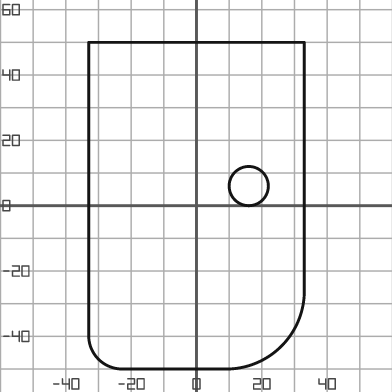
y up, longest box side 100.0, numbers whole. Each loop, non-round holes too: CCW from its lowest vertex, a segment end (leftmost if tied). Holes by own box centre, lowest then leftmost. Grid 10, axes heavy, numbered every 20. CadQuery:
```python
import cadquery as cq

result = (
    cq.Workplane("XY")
    .moveTo(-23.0, -50.0)
    .lineTo(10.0, -50.0)
    .threePointArc((26.0, -43.0), (33.0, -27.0))
    .lineTo(33.0, 50.0)
    .lineTo(-33.0, 50.0)
    .lineTo(-33.0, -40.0)
    .threePointArc((-30.0, -47.0), (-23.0, -50.0))
    .close()
    .moveTo(16.0, 6.0)
    .circle(6.0)
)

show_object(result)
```